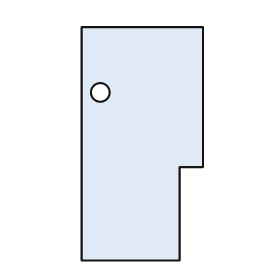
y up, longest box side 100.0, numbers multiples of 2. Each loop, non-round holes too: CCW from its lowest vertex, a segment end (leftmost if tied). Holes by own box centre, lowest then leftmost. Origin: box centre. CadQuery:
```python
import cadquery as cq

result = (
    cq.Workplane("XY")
    .moveTo(-26.0, -50.0)
    .lineTo(16.0, -50.0)
    .lineTo(16.0, -10.0)
    .lineTo(26.0, -10.0)
    .lineTo(26.0, 50.0)
    .lineTo(-26.0, 50.0)
    .close()
    .moveTo(-18.0, 22.0)
    .circle(4.0)
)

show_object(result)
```